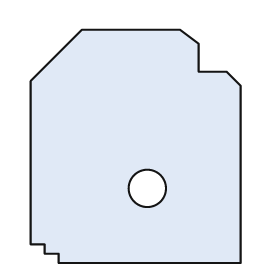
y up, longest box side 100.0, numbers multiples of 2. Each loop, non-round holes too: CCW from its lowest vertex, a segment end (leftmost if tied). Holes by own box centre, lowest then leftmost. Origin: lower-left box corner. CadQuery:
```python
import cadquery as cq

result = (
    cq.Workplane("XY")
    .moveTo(12.0, 0.0)
    .lineTo(90.0, 0.0)
    .lineTo(90.0, 76.0)
    .lineTo(84.0, 82.0)
    .lineTo(72.0, 82.0)
    .lineTo(72.0, 94.0)
    .lineTo(64.0, 100.0)
    .lineTo(22.0, 100.0)
    .lineTo(0.0, 78.0)
    .lineTo(0.0, 8.0)
    .lineTo(6.0, 8.0)
    .lineTo(6.0, 4.0)
    .lineTo(12.0, 4.0)
    .close()
    .moveTo(50.0, 32.0)
    .circle(8.0)
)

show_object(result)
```